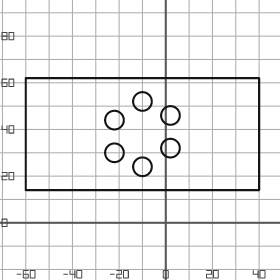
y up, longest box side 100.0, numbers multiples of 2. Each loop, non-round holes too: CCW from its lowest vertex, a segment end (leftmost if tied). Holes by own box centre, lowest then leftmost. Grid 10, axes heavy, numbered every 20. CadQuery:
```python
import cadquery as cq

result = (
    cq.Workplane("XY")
    .moveTo(-60.0, 14.0)
    .lineTo(40.0, 14.0)
    .lineTo(40.0, 62.0)
    .lineTo(-60.0, 62.0)
    .close()
    .moveTo(-10.0, 24.0)
    .circle(4.0)
    .moveTo(-22.0, 30.0)
    .circle(4.0)
    .moveTo(2.0, 32.0)
    .circle(4.0)
    .moveTo(-22.0, 44.0)
    .circle(4.0)
    .moveTo(2.0, 46.0)
    .circle(4.0)
    .moveTo(-10.0, 52.0)
    .circle(4.0)
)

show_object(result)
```